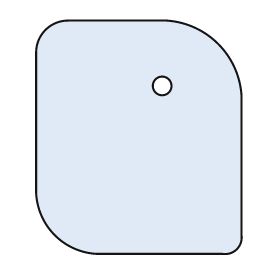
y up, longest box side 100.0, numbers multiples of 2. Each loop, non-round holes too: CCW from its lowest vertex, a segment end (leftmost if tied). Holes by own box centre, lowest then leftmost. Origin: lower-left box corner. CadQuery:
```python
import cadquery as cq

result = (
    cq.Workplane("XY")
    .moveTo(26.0, 0.0)
    .lineTo(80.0, 0.0)
    .threePointArc((86.0, 2.0), (88.0, 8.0))
    .lineTo(88.0, 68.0)
    .threePointArc((78.0, 90.0), (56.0, 100.0))
    .lineTo(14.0, 100.0)
    .threePointArc((4.0, 96.0), (0.0, 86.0))
    .lineTo(0.0, 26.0)
    .threePointArc((8.0, 8.0), (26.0, 0.0))
    .close()
    .moveTo(54.0, 72.0)
    .circle(4.0)
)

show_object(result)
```